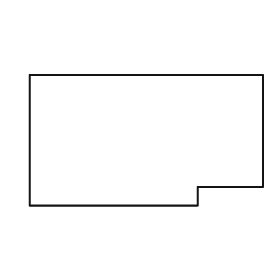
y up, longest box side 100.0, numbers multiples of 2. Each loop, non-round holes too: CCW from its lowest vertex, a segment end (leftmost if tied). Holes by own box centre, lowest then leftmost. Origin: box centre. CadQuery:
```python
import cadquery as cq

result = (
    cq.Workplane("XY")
    .moveTo(-50.0, -28.0)
    .lineTo(22.0, -28.0)
    .lineTo(22.0, -20.0)
    .lineTo(50.0, -20.0)
    .lineTo(50.0, 28.0)
    .lineTo(-50.0, 28.0)
    .close()
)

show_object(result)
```